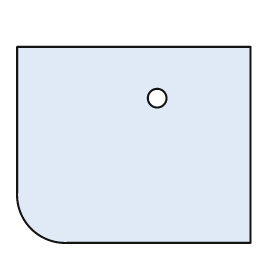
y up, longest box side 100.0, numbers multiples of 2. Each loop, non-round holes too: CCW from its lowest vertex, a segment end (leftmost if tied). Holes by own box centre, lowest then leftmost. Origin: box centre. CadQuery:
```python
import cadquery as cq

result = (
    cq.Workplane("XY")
    .moveTo(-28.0, -42.0)
    .lineTo(50.0, -42.0)
    .lineTo(50.0, 42.0)
    .lineTo(-50.0, 42.0)
    .lineTo(-50.0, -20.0)
    .threePointArc((-44.0, -36.0), (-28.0, -42.0))
    .close()
    .moveTo(10.0, 20.0)
    .circle(4.0)
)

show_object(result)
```